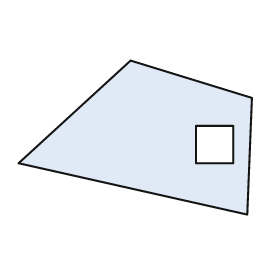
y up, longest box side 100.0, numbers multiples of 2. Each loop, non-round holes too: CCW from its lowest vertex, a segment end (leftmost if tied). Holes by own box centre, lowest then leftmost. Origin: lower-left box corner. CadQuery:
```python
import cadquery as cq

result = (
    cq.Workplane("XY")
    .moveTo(98.0, 0.0)
    .lineTo(100.0, 50.0)
    .lineTo(48.0, 66.0)
    .lineTo(0.0, 22.0)
    .close()
    .moveTo(76.0, 22.0)
    .lineTo(92.0, 22.0)
    .lineTo(92.0, 38.0)
    .lineTo(76.0, 38.0)
    .close()
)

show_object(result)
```